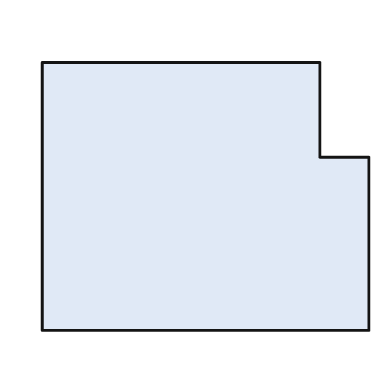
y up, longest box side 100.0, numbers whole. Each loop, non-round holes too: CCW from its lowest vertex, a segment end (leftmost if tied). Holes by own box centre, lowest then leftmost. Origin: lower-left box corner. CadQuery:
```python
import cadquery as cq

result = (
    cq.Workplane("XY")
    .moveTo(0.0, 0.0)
    .lineTo(100.0, 0.0)
    .lineTo(100.0, 53.0)
    .lineTo(85.0, 53.0)
    .lineTo(85.0, 82.0)
    .lineTo(0.0, 82.0)
    .close()
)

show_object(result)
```